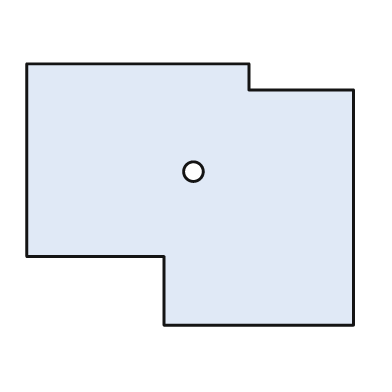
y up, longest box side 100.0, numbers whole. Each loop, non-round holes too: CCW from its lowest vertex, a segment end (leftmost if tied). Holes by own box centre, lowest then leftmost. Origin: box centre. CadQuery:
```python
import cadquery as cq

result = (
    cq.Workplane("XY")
    .moveTo(-8.0, -40.0)
    .lineTo(50.0, -40.0)
    .lineTo(50.0, 32.0)
    .lineTo(18.0, 32.0)
    .lineTo(18.0, 40.0)
    .lineTo(-50.0, 40.0)
    .lineTo(-50.0, -19.0)
    .lineTo(-8.0, -19.0)
    .close()
    .moveTo(1.0, 7.0)
    .circle(3.0)
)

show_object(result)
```